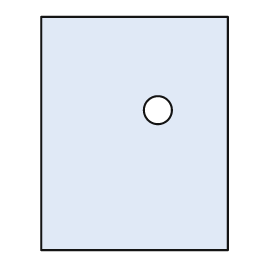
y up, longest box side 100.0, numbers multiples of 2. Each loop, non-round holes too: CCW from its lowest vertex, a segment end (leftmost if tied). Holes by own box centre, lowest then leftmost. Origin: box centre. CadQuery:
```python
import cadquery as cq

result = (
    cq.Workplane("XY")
    .moveTo(-40.0, -50.0)
    .lineTo(40.0, -50.0)
    .lineTo(40.0, 50.0)
    .lineTo(-40.0, 50.0)
    .close()
    .moveTo(10.0, 10.0)
    .circle(6.0)
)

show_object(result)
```